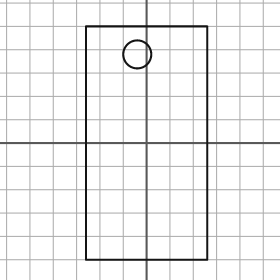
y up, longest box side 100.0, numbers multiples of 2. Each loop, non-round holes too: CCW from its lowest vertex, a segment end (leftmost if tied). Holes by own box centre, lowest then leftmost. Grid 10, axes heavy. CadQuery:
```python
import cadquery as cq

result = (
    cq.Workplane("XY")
    .moveTo(-26.0, -50.0)
    .lineTo(26.0, -50.0)
    .lineTo(26.0, 50.0)
    .lineTo(-26.0, 50.0)
    .close()
    .moveTo(-4.0, 38.0)
    .circle(6.0)
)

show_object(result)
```